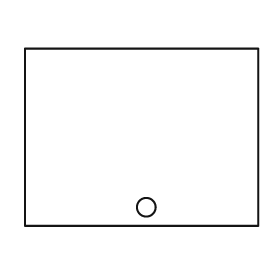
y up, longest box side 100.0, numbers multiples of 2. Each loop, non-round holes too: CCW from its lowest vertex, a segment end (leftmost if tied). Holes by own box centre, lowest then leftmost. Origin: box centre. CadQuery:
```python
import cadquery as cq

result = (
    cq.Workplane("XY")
    .moveTo(-50.0, -38.0)
    .lineTo(50.0, -38.0)
    .lineTo(50.0, 38.0)
    .lineTo(-50.0, 38.0)
    .close()
    .moveTo(2.0, -30.0)
    .circle(4.0)
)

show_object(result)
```